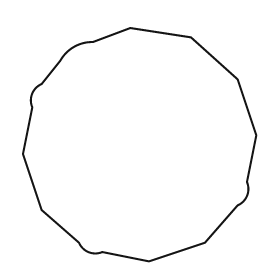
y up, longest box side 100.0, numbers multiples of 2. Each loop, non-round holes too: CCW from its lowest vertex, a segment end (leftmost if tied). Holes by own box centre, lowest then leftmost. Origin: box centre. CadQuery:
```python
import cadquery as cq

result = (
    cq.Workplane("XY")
    .moveTo(4.0, -50.0)
    .lineTo(28.0, -42.0)
    .lineTo(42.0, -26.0)
    .threePointArc((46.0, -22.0), (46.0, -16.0))
    .lineTo(50.0, 4.0)
    .lineTo(42.0, 28.0)
    .lineTo(22.0, 46.0)
    .lineTo(-4.0, 50.0)
    .lineTo(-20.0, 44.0)
    .threePointArc((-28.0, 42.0), (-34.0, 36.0))
    .lineTo(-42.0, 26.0)
    .threePointArc((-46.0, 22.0), (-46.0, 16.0))
    .lineTo(-50.0, -4.0)
    .lineTo(-42.0, -28.0)
    .lineTo(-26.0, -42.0)
    .threePointArc((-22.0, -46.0), (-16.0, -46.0))
    .close()
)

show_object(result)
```